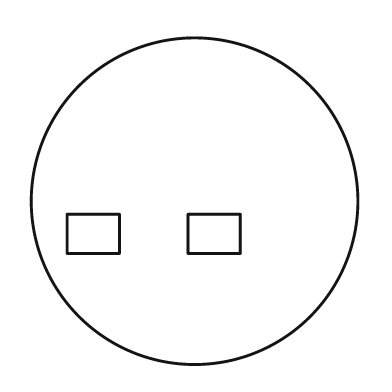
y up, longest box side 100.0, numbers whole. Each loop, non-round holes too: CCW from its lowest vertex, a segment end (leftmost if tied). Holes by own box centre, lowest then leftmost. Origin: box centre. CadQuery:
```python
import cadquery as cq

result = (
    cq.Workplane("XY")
    .moveTo(0.0, 0.0)
    .circle(50.0)
    .moveTo(-39.0, -16.0)
    .lineTo(-23.0, -16.0)
    .lineTo(-23.0, -4.0)
    .lineTo(-39.0, -4.0)
    .close()
    .moveTo(-2.0, -16.0)
    .lineTo(14.0, -16.0)
    .lineTo(14.0, -4.0)
    .lineTo(-2.0, -4.0)
    .close()
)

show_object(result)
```